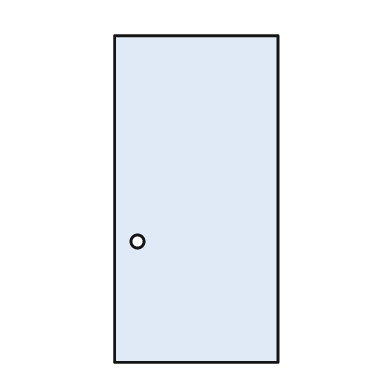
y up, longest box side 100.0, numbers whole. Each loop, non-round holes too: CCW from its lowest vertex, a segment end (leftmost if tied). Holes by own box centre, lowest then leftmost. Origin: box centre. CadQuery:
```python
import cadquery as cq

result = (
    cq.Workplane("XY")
    .moveTo(-25.0, -50.0)
    .lineTo(25.0, -50.0)
    .lineTo(25.0, 50.0)
    .lineTo(-25.0, 50.0)
    .close()
    .moveTo(-18.0, -13.0)
    .circle(2.0)
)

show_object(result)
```